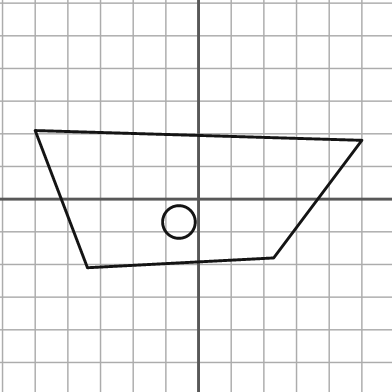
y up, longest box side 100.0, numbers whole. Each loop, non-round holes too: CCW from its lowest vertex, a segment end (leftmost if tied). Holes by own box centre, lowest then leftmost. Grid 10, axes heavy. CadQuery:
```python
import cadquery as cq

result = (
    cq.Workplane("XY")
    .moveTo(-34.0, -21.0)
    .lineTo(23.0, -18.0)
    .lineTo(50.0, 18.0)
    .lineTo(-50.0, 21.0)
    .close()
    .moveTo(-6.0, -7.0)
    .circle(5.0)
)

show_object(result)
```